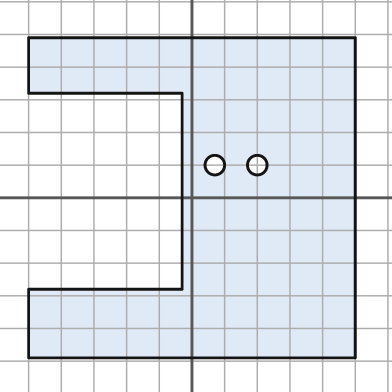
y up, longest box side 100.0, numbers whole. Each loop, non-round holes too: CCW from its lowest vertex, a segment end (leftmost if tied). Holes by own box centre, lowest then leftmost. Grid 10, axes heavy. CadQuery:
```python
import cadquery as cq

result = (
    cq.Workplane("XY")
    .moveTo(-50.0, -49.0)
    .lineTo(50.0, -49.0)
    .lineTo(50.0, 49.0)
    .lineTo(-50.0, 49.0)
    .lineTo(-50.0, 32.0)
    .lineTo(-3.0, 32.0)
    .lineTo(-3.0, -28.0)
    .lineTo(-50.0, -28.0)
    .close()
    .moveTo(7.0, 10.0)
    .circle(3.0)
    .moveTo(20.0, 10.0)
    .circle(3.0)
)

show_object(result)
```